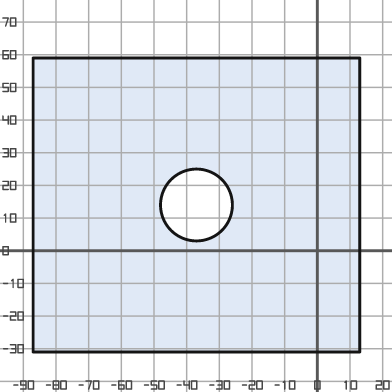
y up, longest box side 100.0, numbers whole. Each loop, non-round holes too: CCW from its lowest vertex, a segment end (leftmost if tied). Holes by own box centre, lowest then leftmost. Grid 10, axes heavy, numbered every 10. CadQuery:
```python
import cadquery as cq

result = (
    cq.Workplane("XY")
    .moveTo(-87.0, -31.0)
    .lineTo(13.0, -31.0)
    .lineTo(13.0, 59.0)
    .lineTo(-87.0, 59.0)
    .close()
    .moveTo(-37.0, 14.0)
    .circle(11.0)
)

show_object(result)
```